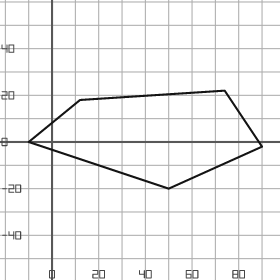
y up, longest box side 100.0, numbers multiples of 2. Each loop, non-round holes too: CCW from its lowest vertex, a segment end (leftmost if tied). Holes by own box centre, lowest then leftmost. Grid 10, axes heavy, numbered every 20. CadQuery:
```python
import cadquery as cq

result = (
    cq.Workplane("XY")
    .moveTo(50.0, -20.0)
    .lineTo(90.0, -2.0)
    .lineTo(74.0, 22.0)
    .lineTo(12.0, 18.0)
    .lineTo(-10.0, 0.0)
    .close()
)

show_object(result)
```